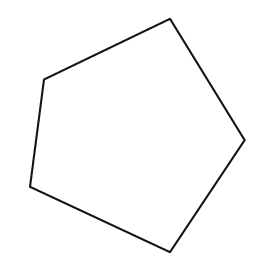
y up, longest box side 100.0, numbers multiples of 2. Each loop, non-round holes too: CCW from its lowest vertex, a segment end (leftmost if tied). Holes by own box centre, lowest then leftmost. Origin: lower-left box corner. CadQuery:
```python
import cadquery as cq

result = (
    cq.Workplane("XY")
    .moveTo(60.0, 0.0)
    .lineTo(92.0, 48.0)
    .lineTo(60.0, 100.0)
    .lineTo(6.0, 74.0)
    .lineTo(0.0, 28.0)
    .close()
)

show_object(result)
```